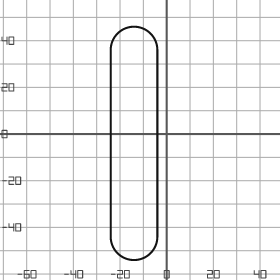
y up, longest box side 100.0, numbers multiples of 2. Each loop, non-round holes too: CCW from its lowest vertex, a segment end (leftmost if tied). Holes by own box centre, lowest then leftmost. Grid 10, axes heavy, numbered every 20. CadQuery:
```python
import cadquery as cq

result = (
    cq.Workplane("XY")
    .moveTo(-24.0, -44.0)
    .threePointArc((-14.0, -54.0), (-4.0, -44.0))
    .lineTo(-4.0, 36.0)
    .threePointArc((-14.0, 46.0), (-24.0, 36.0))
    .close()
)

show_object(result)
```